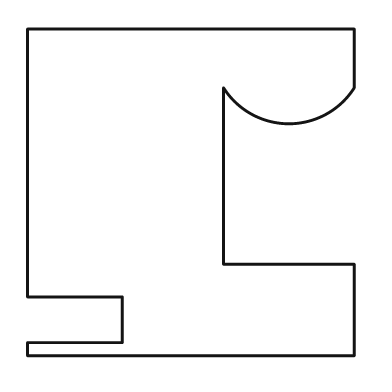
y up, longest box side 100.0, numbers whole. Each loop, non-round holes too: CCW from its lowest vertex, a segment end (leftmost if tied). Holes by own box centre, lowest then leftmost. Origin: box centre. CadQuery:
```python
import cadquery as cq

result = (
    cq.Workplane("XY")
    .moveTo(-50.0, -50.0)
    .lineTo(50.0, -50.0)
    .lineTo(50.0, -22.0)
    .lineTo(10.0, -22.0)
    .lineTo(10.0, 32.0)
    .threePointArc((30.0, 21.0), (50.0, 32.0))
    .lineTo(50.0, 50.0)
    .lineTo(-50.0, 50.0)
    .lineTo(-50.0, -32.0)
    .lineTo(-21.0, -32.0)
    .lineTo(-21.0, -46.0)
    .lineTo(-50.0, -46.0)
    .close()
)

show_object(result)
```